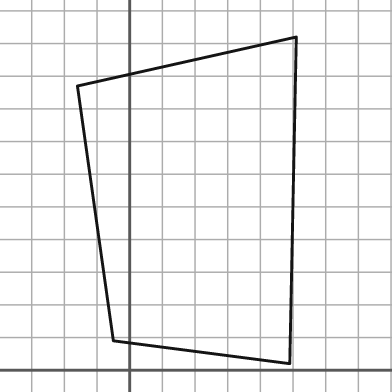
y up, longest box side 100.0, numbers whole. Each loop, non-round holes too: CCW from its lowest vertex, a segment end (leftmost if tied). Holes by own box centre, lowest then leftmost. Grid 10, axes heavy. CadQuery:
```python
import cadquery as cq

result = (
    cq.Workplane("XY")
    .moveTo(49.0, 2.0)
    .lineTo(51.0, 102.0)
    .lineTo(-16.0, 87.0)
    .lineTo(-5.0, 9.0)
    .close()
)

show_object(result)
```